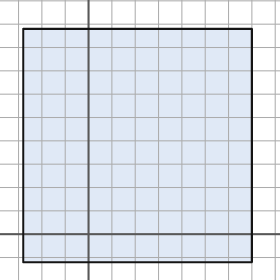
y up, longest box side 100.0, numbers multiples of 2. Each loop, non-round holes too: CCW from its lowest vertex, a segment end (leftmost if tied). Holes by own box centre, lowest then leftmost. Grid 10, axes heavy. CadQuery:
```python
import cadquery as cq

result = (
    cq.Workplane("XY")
    .moveTo(-28.0, -12.0)
    .lineTo(70.0, -12.0)
    .lineTo(70.0, 88.0)
    .lineTo(-28.0, 88.0)
    .close()
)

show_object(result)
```